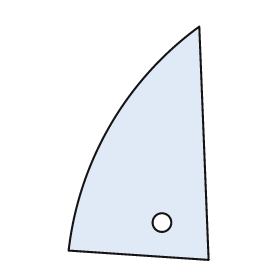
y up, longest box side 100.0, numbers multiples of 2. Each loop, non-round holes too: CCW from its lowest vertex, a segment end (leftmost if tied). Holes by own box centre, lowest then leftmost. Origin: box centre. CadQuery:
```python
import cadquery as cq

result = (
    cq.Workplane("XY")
    .moveTo(30.0, -50.0)
    .lineTo(26.0, 50.0)
    .threePointArc((-12.0, 8.0), (-30.0, -46.0))
    .close()
    .moveTo(10.0, -34.0)
    .circle(4.0)
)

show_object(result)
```